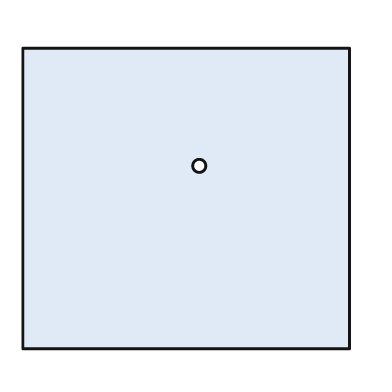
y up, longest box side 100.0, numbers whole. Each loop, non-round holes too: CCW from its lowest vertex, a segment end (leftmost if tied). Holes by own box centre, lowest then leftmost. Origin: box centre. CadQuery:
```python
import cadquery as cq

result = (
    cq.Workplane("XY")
    .moveTo(-50.0, -46.0)
    .lineTo(50.0, -46.0)
    .lineTo(50.0, 46.0)
    .lineTo(-50.0, 46.0)
    .close()
    .moveTo(4.0, 10.0)
    .circle(2.0)
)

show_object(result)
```